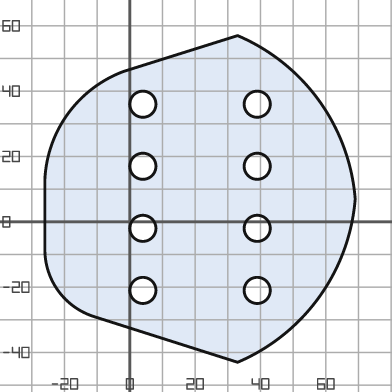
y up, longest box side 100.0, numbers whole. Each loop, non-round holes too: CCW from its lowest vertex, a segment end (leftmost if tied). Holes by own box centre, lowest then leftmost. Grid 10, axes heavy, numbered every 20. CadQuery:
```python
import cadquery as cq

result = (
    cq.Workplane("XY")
    .moveTo(33.0, -43.0)
    .threePointArc((58.0, -23.0), (69.0, 7.0))
    .threePointArc((58.0, 37.0), (33.0, 57.0))
    .lineTo(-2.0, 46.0)
    .threePointArc((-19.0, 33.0), (-26.0, 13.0))
    .lineTo(-26.0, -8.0)
    .threePointArc((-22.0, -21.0), (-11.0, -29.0))
    .close()
    .moveTo(4.0, -21.0)
    .circle(4.0)
    .moveTo(39.0, -21.0)
    .circle(4.0)
    .moveTo(4.0, -2.0)
    .circle(4.0)
    .moveTo(39.0, -2.0)
    .circle(4.0)
    .moveTo(4.0, 17.0)
    .circle(4.0)
    .moveTo(39.0, 17.0)
    .circle(4.0)
    .moveTo(4.0, 36.0)
    .circle(4.0)
    .moveTo(39.0, 36.0)
    .circle(4.0)
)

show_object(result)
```